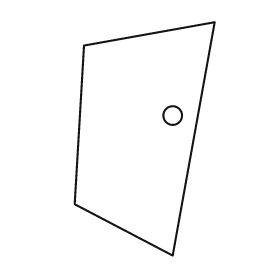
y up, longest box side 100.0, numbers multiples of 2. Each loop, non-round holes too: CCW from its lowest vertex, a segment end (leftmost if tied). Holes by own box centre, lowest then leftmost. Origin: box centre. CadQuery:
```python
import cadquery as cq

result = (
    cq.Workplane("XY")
    .moveTo(12.0, -50.0)
    .lineTo(30.0, 50.0)
    .lineTo(-26.0, 40.0)
    .lineTo(-30.0, -28.0)
    .close()
    .moveTo(12.0, 10.0)
    .circle(4.0)
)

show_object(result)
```